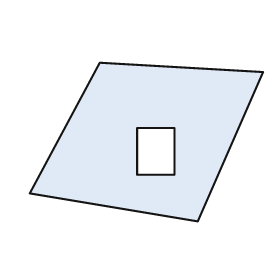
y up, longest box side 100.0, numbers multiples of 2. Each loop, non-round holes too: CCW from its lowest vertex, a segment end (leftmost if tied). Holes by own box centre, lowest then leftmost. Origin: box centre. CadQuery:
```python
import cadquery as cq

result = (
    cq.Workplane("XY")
    .moveTo(22.0, -34.0)
    .lineTo(50.0, 30.0)
    .lineTo(-20.0, 34.0)
    .lineTo(-50.0, -22.0)
    .close()
    .moveTo(-4.0, -14.0)
    .lineTo(12.0, -14.0)
    .lineTo(12.0, 6.0)
    .lineTo(-4.0, 6.0)
    .close()
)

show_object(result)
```